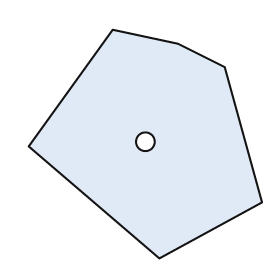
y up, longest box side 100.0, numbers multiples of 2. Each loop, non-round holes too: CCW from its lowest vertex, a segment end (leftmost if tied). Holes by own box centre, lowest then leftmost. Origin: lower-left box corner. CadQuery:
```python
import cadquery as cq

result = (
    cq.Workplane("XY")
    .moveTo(56.0, 0.0)
    .lineTo(100.0, 24.0)
    .lineTo(84.0, 82.0)
    .lineTo(64.0, 92.0)
    .lineTo(36.0, 98.0)
    .lineTo(0.0, 48.0)
    .close()
    .moveTo(50.0, 50.0)
    .circle(4.0)
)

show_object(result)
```